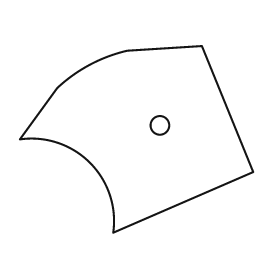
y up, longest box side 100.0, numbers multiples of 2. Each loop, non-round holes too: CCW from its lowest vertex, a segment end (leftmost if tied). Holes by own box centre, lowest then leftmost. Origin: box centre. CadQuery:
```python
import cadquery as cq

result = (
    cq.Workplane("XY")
    .moveTo(-10.0, -40.0)
    .lineTo(50.0, -14.0)
    .lineTo(28.0, 40.0)
    .lineTo(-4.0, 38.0)
    .threePointArc((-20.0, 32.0), (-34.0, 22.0))
    .lineTo(-50.0, 0.0)
    .threePointArc((-20.0, -10.0), (-10.0, -40.0))
    .close()
    .moveTo(10.0, 6.0)
    .circle(4.0)
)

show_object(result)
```